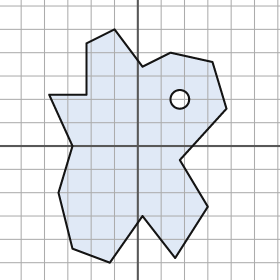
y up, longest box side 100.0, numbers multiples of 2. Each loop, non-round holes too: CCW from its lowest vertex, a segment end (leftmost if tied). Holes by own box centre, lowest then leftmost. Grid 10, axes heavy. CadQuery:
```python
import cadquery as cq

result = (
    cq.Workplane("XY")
    .moveTo(-12.0, -50.0)
    .lineTo(2.0, -30.0)
    .lineTo(16.0, -48.0)
    .lineTo(30.0, -26.0)
    .lineTo(18.0, -6.0)
    .lineTo(38.0, 16.0)
    .lineTo(32.0, 36.0)
    .lineTo(14.0, 40.0)
    .lineTo(2.0, 34.0)
    .lineTo(-10.0, 50.0)
    .lineTo(-22.0, 44.0)
    .lineTo(-22.0, 22.0)
    .lineTo(-38.0, 22.0)
    .lineTo(-28.0, 0.0)
    .lineTo(-34.0, -20.0)
    .lineTo(-28.0, -44.0)
    .close()
    .moveTo(18.0, 20.0)
    .circle(4.0)
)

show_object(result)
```